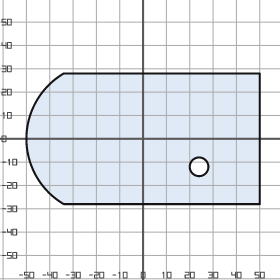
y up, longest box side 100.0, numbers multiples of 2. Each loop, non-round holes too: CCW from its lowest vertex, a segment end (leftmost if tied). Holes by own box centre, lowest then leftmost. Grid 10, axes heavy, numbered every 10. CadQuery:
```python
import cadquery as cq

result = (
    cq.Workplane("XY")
    .moveTo(-34.0, -28.0)
    .lineTo(50.0, -28.0)
    .lineTo(50.0, 28.0)
    .lineTo(-34.0, 28.0)
    .threePointArc((-50.0, 0.0), (-34.0, -28.0))
    .close()
    .moveTo(24.0, -12.0)
    .circle(4.0)
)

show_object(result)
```